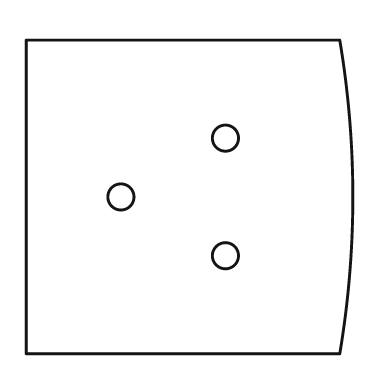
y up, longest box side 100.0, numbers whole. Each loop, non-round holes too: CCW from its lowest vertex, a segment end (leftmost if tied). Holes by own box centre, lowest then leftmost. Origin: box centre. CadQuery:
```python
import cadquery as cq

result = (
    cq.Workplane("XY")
    .moveTo(-50.0, -48.0)
    .lineTo(46.0, -48.0)
    .threePointArc((50.0, 0.0), (46.0, 48.0))
    .lineTo(-50.0, 48.0)
    .close()
    .moveTo(11.0, -18.0)
    .circle(4.0)
    .moveTo(-21.0, 0.0)
    .circle(4.0)
    .moveTo(11.0, 18.0)
    .circle(4.0)
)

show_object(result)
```